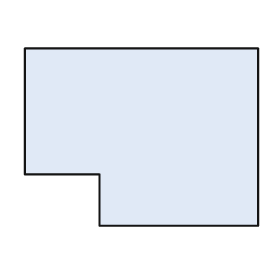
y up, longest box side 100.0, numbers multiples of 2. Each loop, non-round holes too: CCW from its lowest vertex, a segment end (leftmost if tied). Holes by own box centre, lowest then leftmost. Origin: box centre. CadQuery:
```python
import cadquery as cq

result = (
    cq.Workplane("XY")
    .moveTo(-18.0, -38.0)
    .lineTo(50.0, -38.0)
    .lineTo(50.0, 38.0)
    .lineTo(-50.0, 38.0)
    .lineTo(-50.0, -16.0)
    .lineTo(-18.0, -16.0)
    .close()
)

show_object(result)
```